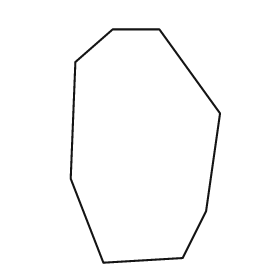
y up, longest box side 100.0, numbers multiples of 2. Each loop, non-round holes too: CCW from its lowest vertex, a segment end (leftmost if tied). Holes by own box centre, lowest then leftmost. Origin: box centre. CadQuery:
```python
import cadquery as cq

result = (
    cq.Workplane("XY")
    .moveTo(-18.0, -50.0)
    .lineTo(16.0, -48.0)
    .lineTo(26.0, -28.0)
    .lineTo(32.0, 14.0)
    .lineTo(6.0, 50.0)
    .lineTo(-14.0, 50.0)
    .lineTo(-30.0, 36.0)
    .lineTo(-32.0, -14.0)
    .close()
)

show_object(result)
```